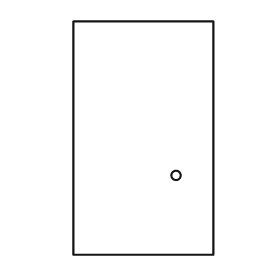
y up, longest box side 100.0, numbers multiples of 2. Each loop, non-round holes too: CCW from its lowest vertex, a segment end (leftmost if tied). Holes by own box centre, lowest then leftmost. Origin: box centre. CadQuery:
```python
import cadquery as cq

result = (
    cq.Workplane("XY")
    .moveTo(-30.0, -50.0)
    .lineTo(30.0, -50.0)
    .lineTo(30.0, 50.0)
    .lineTo(-30.0, 50.0)
    .close()
    .moveTo(14.0, -16.0)
    .circle(2.0)
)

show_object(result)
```